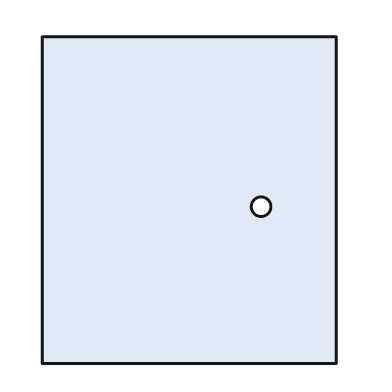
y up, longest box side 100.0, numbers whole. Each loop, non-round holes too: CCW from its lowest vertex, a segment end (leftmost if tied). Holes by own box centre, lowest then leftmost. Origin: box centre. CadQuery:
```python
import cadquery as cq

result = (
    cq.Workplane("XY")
    .moveTo(-45.0, -50.0)
    .lineTo(45.0, -50.0)
    .lineTo(45.0, 50.0)
    .lineTo(-45.0, 50.0)
    .close()
    .moveTo(22.0, -2.0)
    .circle(3.0)
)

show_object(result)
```